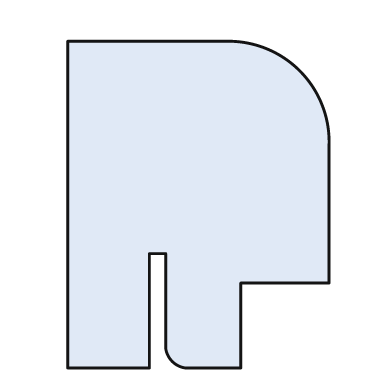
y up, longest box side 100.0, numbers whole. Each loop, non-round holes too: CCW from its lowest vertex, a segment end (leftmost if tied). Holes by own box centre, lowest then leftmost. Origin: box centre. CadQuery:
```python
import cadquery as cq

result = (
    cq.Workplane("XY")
    .moveTo(-40.0, -50.0)
    .lineTo(-15.0, -50.0)
    .lineTo(-15.0, -15.0)
    .lineTo(-10.0, -15.0)
    .lineTo(-10.0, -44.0)
    .threePointArc((-8.0, -48.0), (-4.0, -50.0))
    .lineTo(13.0, -50.0)
    .lineTo(13.0, -24.0)
    .lineTo(40.0, -24.0)
    .lineTo(40.0, 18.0)
    .threePointArc((31.0, 41.0), (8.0, 50.0))
    .lineTo(-40.0, 50.0)
    .close()
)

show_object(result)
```